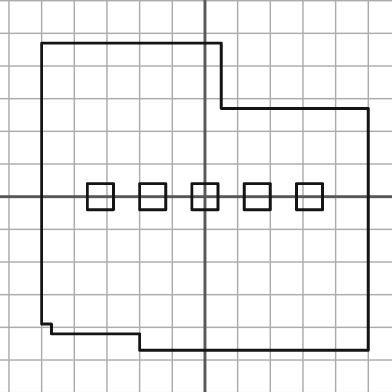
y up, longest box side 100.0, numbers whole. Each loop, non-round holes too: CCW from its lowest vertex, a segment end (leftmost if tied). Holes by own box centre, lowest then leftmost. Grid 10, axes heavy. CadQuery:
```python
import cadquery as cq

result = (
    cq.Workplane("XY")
    .moveTo(-20.0, -47.0)
    .lineTo(50.0, -47.0)
    .lineTo(50.0, 27.0)
    .lineTo(5.0, 27.0)
    .lineTo(5.0, 47.0)
    .lineTo(-50.0, 47.0)
    .lineTo(-50.0, -39.0)
    .lineTo(-47.0, -39.0)
    .lineTo(-47.0, -42.0)
    .lineTo(-20.0, -42.0)
    .close()
    .moveTo(-36.0, -4.0)
    .lineTo(-28.0, -4.0)
    .lineTo(-28.0, 4.0)
    .lineTo(-36.0, 4.0)
    .close()
    .moveTo(-20.0, -4.0)
    .lineTo(-12.0, -4.0)
    .lineTo(-12.0, 4.0)
    .lineTo(-20.0, 4.0)
    .close()
    .moveTo(-4.0, -4.0)
    .lineTo(4.0, -4.0)
    .lineTo(4.0, 4.0)
    .lineTo(-4.0, 4.0)
    .close()
    .moveTo(12.0, -4.0)
    .lineTo(20.0, -4.0)
    .lineTo(20.0, 4.0)
    .lineTo(12.0, 4.0)
    .close()
    .moveTo(28.0, -4.0)
    .lineTo(36.0, -4.0)
    .lineTo(36.0, 4.0)
    .lineTo(28.0, 4.0)
    .close()
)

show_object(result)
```